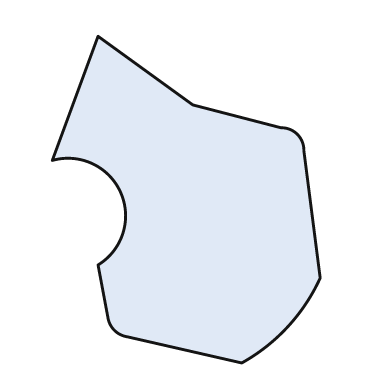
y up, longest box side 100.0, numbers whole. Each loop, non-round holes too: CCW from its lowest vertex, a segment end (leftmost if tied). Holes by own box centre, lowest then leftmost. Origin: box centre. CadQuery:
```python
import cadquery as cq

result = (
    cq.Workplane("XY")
    .moveTo(17.0, -50.0)
    .threePointArc((31.0, -39.0), (41.0, -24.0))
    .lineTo(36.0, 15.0)
    .threePointArc((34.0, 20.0), (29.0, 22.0))
    .lineTo(2.0, 29.0)
    .lineTo(-27.0, 50.0)
    .lineTo(-41.0, 12.0)
    .threePointArc((-20.0, 2.0), (-27.0, -20.0))
    .lineTo(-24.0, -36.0)
    .threePointArc((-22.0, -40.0), (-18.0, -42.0))
    .close()
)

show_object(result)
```